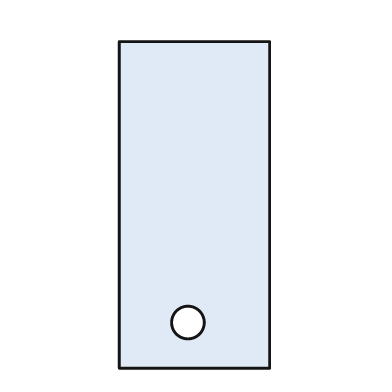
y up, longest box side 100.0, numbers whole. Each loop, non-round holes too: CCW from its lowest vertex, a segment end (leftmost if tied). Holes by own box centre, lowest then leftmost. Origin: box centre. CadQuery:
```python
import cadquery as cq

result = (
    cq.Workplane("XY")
    .moveTo(-23.0, -50.0)
    .lineTo(23.0, -50.0)
    .lineTo(23.0, 50.0)
    .lineTo(-23.0, 50.0)
    .close()
    .moveTo(-2.0, -36.0)
    .circle(5.0)
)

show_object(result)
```